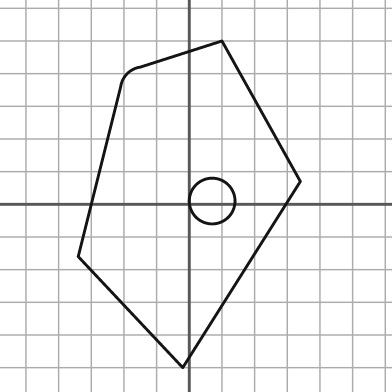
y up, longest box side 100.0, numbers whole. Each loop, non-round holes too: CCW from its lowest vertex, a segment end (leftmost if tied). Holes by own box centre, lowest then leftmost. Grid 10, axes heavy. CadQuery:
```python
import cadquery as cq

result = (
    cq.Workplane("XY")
    .moveTo(-2.0, -50.0)
    .lineTo(34.0, 7.0)
    .lineTo(10.0, 50.0)
    .lineTo(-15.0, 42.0)
    .threePointArc((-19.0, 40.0), (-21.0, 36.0))
    .lineTo(-34.0, -16.0)
    .close()
    .moveTo(7.0, 1.0)
    .circle(7.0)
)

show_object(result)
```